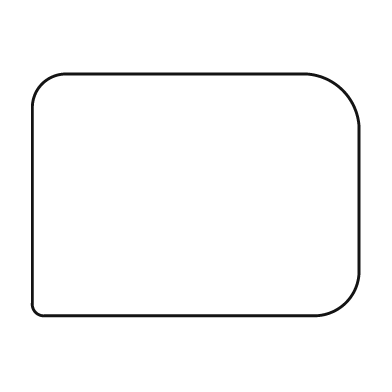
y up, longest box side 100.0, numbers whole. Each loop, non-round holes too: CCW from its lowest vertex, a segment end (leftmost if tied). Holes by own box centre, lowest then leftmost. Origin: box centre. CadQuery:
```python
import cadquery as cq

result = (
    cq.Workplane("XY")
    .moveTo(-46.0, -37.0)
    .lineTo(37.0, -37.0)
    .threePointArc((46.0, -33.0), (50.0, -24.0))
    .lineTo(50.0, 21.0)
    .threePointArc((45.0, 32.0), (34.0, 37.0))
    .lineTo(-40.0, 37.0)
    .threePointArc((-47.0, 34.0), (-50.0, 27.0))
    .lineTo(-50.0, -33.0)
    .threePointArc((-49.0, -36.0), (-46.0, -37.0))
    .close()
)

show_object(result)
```